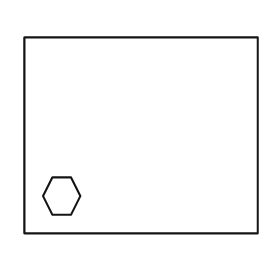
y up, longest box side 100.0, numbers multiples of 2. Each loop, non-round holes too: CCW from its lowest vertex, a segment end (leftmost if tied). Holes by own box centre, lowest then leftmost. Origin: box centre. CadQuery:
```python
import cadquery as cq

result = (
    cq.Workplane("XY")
    .moveTo(-50.0, -42.0)
    .lineTo(50.0, -42.0)
    .lineTo(50.0, 42.0)
    .lineTo(-50.0, 42.0)
    .close()
    .moveTo(-38.0, -34.0)
    .lineTo(-30.0, -34.0)
    .lineTo(-26.0, -26.0)
    .lineTo(-30.0, -18.0)
    .lineTo(-38.0, -18.0)
    .lineTo(-42.0, -26.0)
    .close()
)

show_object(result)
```